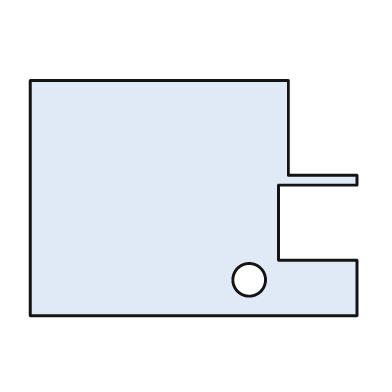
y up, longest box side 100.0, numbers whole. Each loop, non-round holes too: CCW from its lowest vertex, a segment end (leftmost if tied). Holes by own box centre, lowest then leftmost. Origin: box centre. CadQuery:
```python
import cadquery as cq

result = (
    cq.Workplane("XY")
    .moveTo(-50.0, -36.0)
    .lineTo(50.0, -36.0)
    .lineTo(50.0, -19.0)
    .lineTo(26.0, -19.0)
    .lineTo(26.0, 4.0)
    .lineTo(50.0, 4.0)
    .lineTo(50.0, 7.0)
    .lineTo(29.0, 7.0)
    .lineTo(29.0, 36.0)
    .lineTo(-50.0, 36.0)
    .close()
    .moveTo(17.0, -25.0)
    .circle(5.0)
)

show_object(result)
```